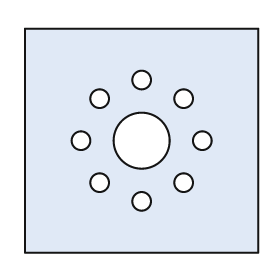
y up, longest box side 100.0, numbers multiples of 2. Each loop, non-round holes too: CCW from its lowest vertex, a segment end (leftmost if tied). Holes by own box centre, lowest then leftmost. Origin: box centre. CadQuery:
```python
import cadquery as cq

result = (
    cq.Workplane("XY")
    .moveTo(-50.0, -48.0)
    .lineTo(50.0, -48.0)
    .lineTo(50.0, 48.0)
    .lineTo(-50.0, 48.0)
    .close()
    .moveTo(0.0, -26.0)
    .circle(4.0)
    .moveTo(-18.0, -18.0)
    .circle(4.0)
    .moveTo(18.0, -18.0)
    .circle(4.0)
    .moveTo(-26.0, 0.0)
    .circle(4.0)
    .moveTo(0.0, 0.0)
    .circle(12.0)
    .moveTo(26.0, 0.0)
    .circle(4.0)
    .moveTo(-18.0, 18.0)
    .circle(4.0)
    .moveTo(18.0, 18.0)
    .circle(4.0)
    .moveTo(0.0, 26.0)
    .circle(4.0)
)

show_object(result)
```